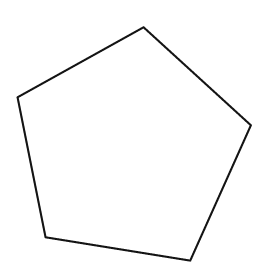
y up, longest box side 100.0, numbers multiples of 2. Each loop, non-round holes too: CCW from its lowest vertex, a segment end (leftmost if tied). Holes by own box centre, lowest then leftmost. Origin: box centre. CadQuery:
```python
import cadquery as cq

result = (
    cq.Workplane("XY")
    .moveTo(24.0, -50.0)
    .lineTo(50.0, 8.0)
    .lineTo(4.0, 50.0)
    .lineTo(-50.0, 20.0)
    .lineTo(-38.0, -40.0)
    .close()
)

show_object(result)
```